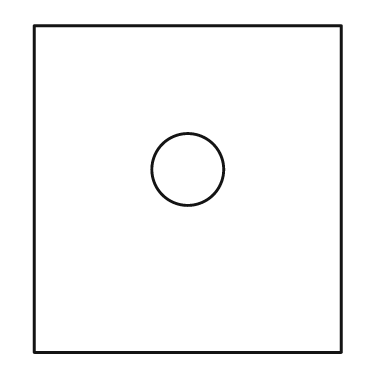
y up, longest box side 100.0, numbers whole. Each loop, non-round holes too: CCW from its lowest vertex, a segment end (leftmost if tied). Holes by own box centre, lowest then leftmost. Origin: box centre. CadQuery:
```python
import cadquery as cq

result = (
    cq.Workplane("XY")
    .moveTo(-47.0, -50.0)
    .lineTo(47.0, -50.0)
    .lineTo(47.0, 50.0)
    .lineTo(-47.0, 50.0)
    .close()
    .moveTo(0.0, 6.0)
    .circle(11.0)
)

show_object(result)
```